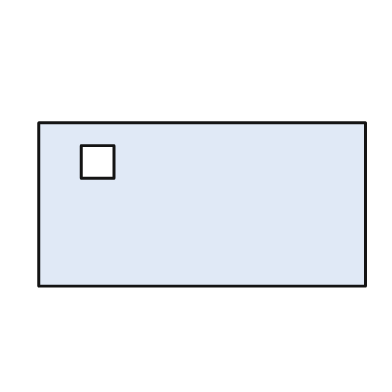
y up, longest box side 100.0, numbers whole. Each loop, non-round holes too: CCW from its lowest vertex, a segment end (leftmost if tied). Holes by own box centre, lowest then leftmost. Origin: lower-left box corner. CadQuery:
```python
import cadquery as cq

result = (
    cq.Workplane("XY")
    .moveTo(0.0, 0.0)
    .lineTo(100.0, 0.0)
    .lineTo(100.0, 50.0)
    .lineTo(0.0, 50.0)
    .close()
    .moveTo(13.0, 33.0)
    .lineTo(23.0, 33.0)
    .lineTo(23.0, 43.0)
    .lineTo(13.0, 43.0)
    .close()
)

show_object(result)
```